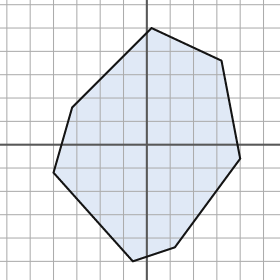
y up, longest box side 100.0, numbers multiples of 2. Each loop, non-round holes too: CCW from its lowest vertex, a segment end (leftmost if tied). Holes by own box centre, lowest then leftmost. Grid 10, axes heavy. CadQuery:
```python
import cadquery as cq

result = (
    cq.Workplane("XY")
    .moveTo(-6.0, -50.0)
    .lineTo(12.0, -44.0)
    .lineTo(40.0, -6.0)
    .lineTo(32.0, 36.0)
    .lineTo(2.0, 50.0)
    .lineTo(-32.0, 16.0)
    .lineTo(-40.0, -12.0)
    .close()
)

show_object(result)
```